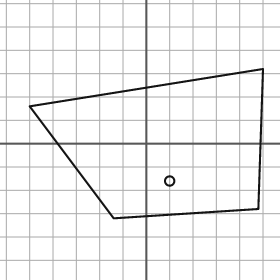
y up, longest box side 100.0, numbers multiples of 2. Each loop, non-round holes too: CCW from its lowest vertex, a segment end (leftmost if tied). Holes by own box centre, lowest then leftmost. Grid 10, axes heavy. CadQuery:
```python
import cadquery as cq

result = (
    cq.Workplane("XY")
    .moveTo(-14.0, -32.0)
    .lineTo(48.0, -28.0)
    .lineTo(50.0, 32.0)
    .lineTo(-50.0, 16.0)
    .close()
    .moveTo(10.0, -16.0)
    .circle(2.0)
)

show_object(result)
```